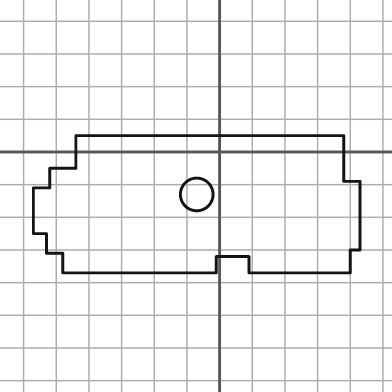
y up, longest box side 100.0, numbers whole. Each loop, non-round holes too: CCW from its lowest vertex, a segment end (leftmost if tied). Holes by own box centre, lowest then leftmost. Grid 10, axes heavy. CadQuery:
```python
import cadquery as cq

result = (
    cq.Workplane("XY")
    .moveTo(-48.0, -37.0)
    .lineTo(-1.0, -37.0)
    .lineTo(-1.0, -32.0)
    .lineTo(9.0, -32.0)
    .lineTo(9.0, -37.0)
    .lineTo(40.0, -37.0)
    .lineTo(40.0, -30.0)
    .lineTo(43.0, -30.0)
    .lineTo(43.0, -9.0)
    .lineTo(38.0, -9.0)
    .lineTo(38.0, 5.0)
    .lineTo(-44.0, 5.0)
    .lineTo(-44.0, -5.0)
    .lineTo(-52.0, -5.0)
    .lineTo(-52.0, -11.0)
    .lineTo(-57.0, -11.0)
    .lineTo(-57.0, -25.0)
    .lineTo(-53.0, -25.0)
    .lineTo(-53.0, -31.0)
    .lineTo(-48.0, -31.0)
    .close()
    .moveTo(-7.0, -13.0)
    .circle(5.0)
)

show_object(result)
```